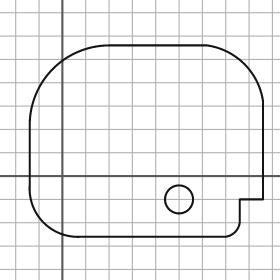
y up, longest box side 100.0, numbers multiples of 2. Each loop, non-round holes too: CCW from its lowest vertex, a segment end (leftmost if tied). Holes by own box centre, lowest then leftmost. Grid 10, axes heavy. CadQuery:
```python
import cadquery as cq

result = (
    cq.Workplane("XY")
    .moveTo(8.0, -26.0)
    .lineTo(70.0, -26.0)
    .threePointArc((74.0, -24.0), (76.0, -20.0))
    .lineTo(76.0, -10.0)
    .lineTo(86.0, -10.0)
    .lineTo(86.0, 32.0)
    .threePointArc((78.0, 48.0), (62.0, 56.0))
    .lineTo(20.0, 56.0)
    .threePointArc((-4.0, 46.0), (-14.0, 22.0))
    .lineTo(-14.0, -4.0)
    .threePointArc((-8.0, -20.0), (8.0, -26.0))
    .close()
    .moveTo(50.0, -10.0)
    .circle(6.0)
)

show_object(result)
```